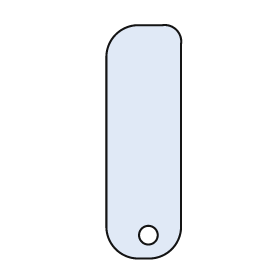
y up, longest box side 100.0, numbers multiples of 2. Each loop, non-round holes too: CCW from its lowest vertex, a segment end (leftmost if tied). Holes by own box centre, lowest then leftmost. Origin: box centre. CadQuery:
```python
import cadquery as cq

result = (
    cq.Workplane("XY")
    .moveTo(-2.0, -50.0)
    .lineTo(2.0, -50.0)
    .threePointArc((12.0, -46.0), (16.0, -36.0))
    .lineTo(16.0, 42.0)
    .threePointArc((14.0, 48.0), (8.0, 50.0))
    .lineTo(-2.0, 50.0)
    .threePointArc((-12.0, 46.0), (-16.0, 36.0))
    .lineTo(-16.0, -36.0)
    .threePointArc((-12.0, -46.0), (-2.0, -50.0))
    .close()
    .moveTo(2.0, -40.0)
    .circle(4.0)
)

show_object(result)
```